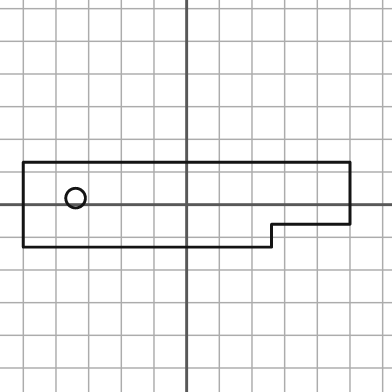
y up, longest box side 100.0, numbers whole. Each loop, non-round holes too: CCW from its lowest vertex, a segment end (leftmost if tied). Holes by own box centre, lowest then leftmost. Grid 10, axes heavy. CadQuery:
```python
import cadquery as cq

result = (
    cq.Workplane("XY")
    .moveTo(-50.0, -13.0)
    .lineTo(26.0, -13.0)
    .lineTo(26.0, -6.0)
    .lineTo(50.0, -6.0)
    .lineTo(50.0, 13.0)
    .lineTo(-50.0, 13.0)
    .close()
    .moveTo(-34.0, 2.0)
    .circle(3.0)
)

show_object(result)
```